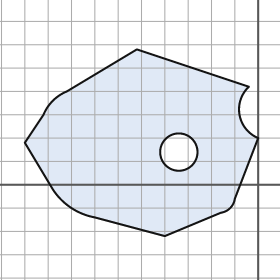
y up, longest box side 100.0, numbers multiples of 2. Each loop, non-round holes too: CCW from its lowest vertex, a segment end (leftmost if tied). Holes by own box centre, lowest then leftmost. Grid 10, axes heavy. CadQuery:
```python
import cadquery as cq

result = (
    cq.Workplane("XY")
    .moveTo(-40.0, -22.0)
    .lineTo(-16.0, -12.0)
    .threePointArc((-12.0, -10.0), (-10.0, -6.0))
    .lineTo(0.0, 20.0)
    .threePointArc((-8.0, 30.0), (-4.0, 42.0))
    .lineTo(-52.0, 58.0)
    .lineTo(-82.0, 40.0)
    .threePointArc((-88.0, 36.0), (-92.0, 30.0))
    .lineTo(-100.0, 18.0)
    .lineTo(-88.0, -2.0)
    .threePointArc((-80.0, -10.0), (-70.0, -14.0))
    .close()
    .moveTo(-34.0, 14.0)
    .circle(8.0)
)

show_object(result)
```